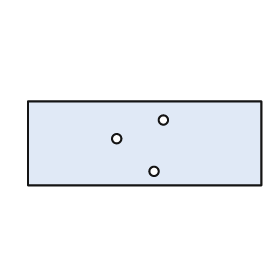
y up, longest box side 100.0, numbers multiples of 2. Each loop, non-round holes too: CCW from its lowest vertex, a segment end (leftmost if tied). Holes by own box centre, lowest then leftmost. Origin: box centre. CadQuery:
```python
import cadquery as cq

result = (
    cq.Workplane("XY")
    .moveTo(-50.0, -18.0)
    .lineTo(50.0, -18.0)
    .lineTo(50.0, 18.0)
    .lineTo(-50.0, 18.0)
    .close()
    .moveTo(4.0, -12.0)
    .circle(2.0)
    .moveTo(-12.0, 2.0)
    .circle(2.0)
    .moveTo(8.0, 10.0)
    .circle(2.0)
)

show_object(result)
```